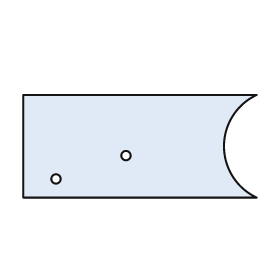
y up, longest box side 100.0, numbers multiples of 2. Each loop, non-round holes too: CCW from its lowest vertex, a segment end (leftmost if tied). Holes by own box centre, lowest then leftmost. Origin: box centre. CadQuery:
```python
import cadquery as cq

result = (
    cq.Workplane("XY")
    .moveTo(-50.0, -22.0)
    .lineTo(50.0, -22.0)
    .threePointArc((36.0, 0.0), (50.0, 22.0))
    .lineTo(-50.0, 22.0)
    .close()
    .moveTo(-36.0, -14.0)
    .circle(2.0)
    .moveTo(-6.0, -4.0)
    .circle(2.0)
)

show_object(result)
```